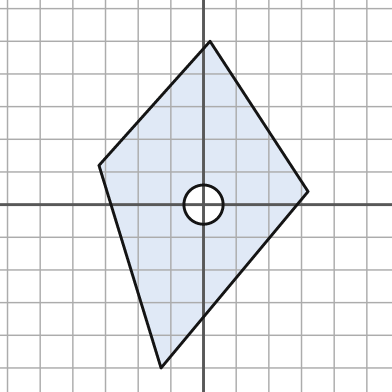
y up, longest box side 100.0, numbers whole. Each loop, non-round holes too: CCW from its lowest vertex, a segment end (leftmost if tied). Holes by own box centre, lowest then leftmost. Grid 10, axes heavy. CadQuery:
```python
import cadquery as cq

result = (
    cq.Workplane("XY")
    .moveTo(-13.0, -50.0)
    .lineTo(32.0, 4.0)
    .lineTo(2.0, 50.0)
    .lineTo(-32.0, 12.0)
    .close()
    .moveTo(0.0, 0.0)
    .circle(6.0)
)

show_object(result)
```